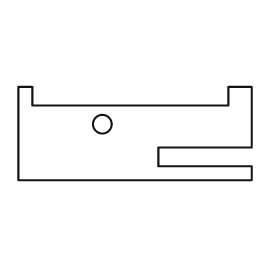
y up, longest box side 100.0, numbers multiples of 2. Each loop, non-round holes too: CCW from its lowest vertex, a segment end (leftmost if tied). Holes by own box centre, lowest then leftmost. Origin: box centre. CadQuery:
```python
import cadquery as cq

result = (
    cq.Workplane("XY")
    .moveTo(-50.0, -20.0)
    .lineTo(50.0, -20.0)
    .lineTo(50.0, -14.0)
    .lineTo(10.0, -14.0)
    .lineTo(10.0, -6.0)
    .lineTo(50.0, -6.0)
    .lineTo(50.0, 20.0)
    .lineTo(40.0, 20.0)
    .lineTo(40.0, 12.0)
    .lineTo(-44.0, 12.0)
    .lineTo(-44.0, 20.0)
    .lineTo(-50.0, 20.0)
    .close()
    .moveTo(-14.0, 4.0)
    .circle(4.0)
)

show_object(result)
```